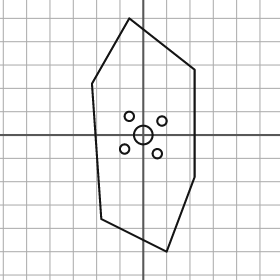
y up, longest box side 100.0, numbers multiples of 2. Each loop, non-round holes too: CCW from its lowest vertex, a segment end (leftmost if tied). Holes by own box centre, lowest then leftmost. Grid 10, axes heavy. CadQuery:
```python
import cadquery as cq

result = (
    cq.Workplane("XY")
    .moveTo(10.0, -50.0)
    .lineTo(22.0, -18.0)
    .lineTo(22.0, 28.0)
    .lineTo(-6.0, 50.0)
    .lineTo(-22.0, 22.0)
    .lineTo(-18.0, -36.0)
    .close()
    .moveTo(6.0, -8.0)
    .circle(2.0)
    .moveTo(-8.0, -6.0)
    .circle(2.0)
    .moveTo(0.0, 0.0)
    .circle(4.0)
    .moveTo(8.0, 6.0)
    .circle(2.0)
    .moveTo(-6.0, 8.0)
    .circle(2.0)
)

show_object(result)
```